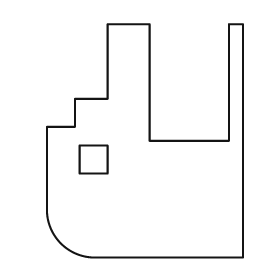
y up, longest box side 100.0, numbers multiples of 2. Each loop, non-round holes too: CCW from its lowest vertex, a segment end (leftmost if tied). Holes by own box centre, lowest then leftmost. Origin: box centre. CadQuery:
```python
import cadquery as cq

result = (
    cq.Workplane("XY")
    .moveTo(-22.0, -50.0)
    .lineTo(42.0, -50.0)
    .lineTo(42.0, 50.0)
    .lineTo(36.0, 50.0)
    .lineTo(36.0, 0.0)
    .lineTo(2.0, 0.0)
    .lineTo(2.0, 50.0)
    .lineTo(-16.0, 50.0)
    .lineTo(-16.0, 18.0)
    .lineTo(-30.0, 18.0)
    .lineTo(-30.0, 6.0)
    .lineTo(-42.0, 6.0)
    .lineTo(-42.0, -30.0)
    .threePointArc((-36.0, -44.0), (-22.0, -50.0))
    .close()
    .moveTo(-28.0, -14.0)
    .lineTo(-16.0, -14.0)
    .lineTo(-16.0, -2.0)
    .lineTo(-28.0, -2.0)
    .close()
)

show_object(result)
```